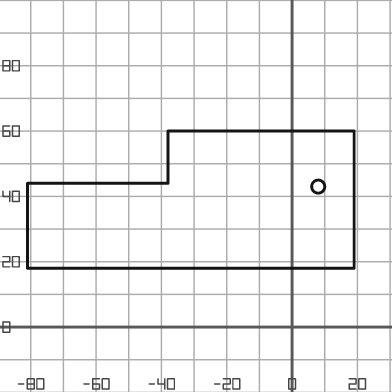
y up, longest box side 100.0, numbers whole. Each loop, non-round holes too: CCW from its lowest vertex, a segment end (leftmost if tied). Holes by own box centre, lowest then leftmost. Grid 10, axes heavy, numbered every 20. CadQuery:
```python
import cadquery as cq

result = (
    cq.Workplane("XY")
    .moveTo(-81.0, 18.0)
    .lineTo(19.0, 18.0)
    .lineTo(19.0, 60.0)
    .lineTo(-38.0, 60.0)
    .lineTo(-38.0, 44.0)
    .lineTo(-81.0, 44.0)
    .close()
    .moveTo(8.0, 43.0)
    .circle(2.0)
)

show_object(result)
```